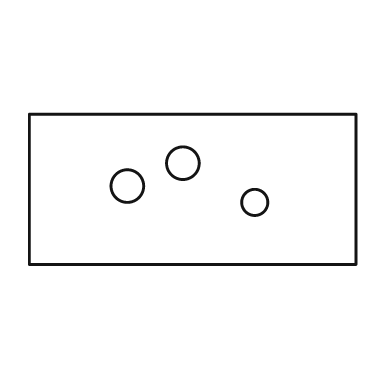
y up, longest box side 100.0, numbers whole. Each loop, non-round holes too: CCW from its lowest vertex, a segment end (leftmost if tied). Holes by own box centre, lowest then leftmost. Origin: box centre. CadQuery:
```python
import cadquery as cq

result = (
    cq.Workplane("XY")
    .moveTo(-50.0, -23.0)
    .lineTo(50.0, -23.0)
    .lineTo(50.0, 23.0)
    .lineTo(-50.0, 23.0)
    .close()
    .moveTo(19.0, -4.0)
    .circle(4.0)
    .moveTo(-20.0, 1.0)
    .circle(5.0)
    .moveTo(-3.0, 8.0)
    .circle(5.0)
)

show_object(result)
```